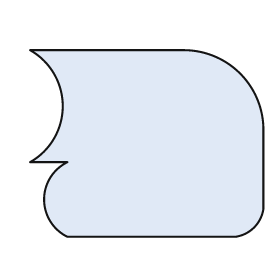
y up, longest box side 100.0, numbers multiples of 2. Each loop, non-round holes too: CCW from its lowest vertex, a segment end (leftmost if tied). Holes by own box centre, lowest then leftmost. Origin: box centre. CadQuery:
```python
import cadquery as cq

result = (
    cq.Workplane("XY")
    .moveTo(-34.0, -40.0)
    .lineTo(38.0, -40.0)
    .threePointArc((46.0, -36.0), (50.0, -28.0))
    .lineTo(50.0, 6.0)
    .threePointArc((40.0, 30.0), (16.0, 40.0))
    .lineTo(-50.0, 40.0)
    .threePointArc((-36.0, 16.0), (-50.0, -8.0))
    .lineTo(-34.0, -8.0)
    .threePointArc((-44.0, -24.0), (-34.0, -40.0))
    .close()
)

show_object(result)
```